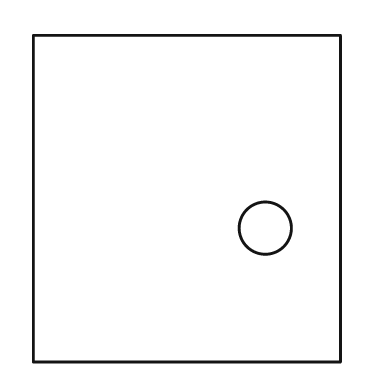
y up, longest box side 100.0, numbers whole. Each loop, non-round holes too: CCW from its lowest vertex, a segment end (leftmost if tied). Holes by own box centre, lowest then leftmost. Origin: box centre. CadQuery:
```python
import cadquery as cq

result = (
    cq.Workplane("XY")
    .moveTo(-47.0, -50.0)
    .lineTo(47.0, -50.0)
    .lineTo(47.0, 50.0)
    .lineTo(-47.0, 50.0)
    .close()
    .moveTo(24.0, -9.0)
    .circle(8.0)
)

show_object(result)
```